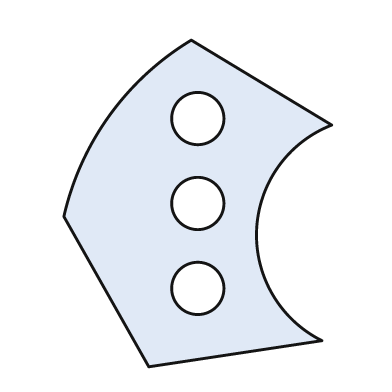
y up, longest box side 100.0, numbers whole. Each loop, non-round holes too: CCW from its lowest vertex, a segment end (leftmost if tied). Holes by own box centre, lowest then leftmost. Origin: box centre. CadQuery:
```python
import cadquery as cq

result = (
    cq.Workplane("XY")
    .moveTo(-15.0, -50.0)
    .lineTo(38.0, -42.0)
    .threePointArc((18.0, -8.0), (41.0, 24.0))
    .lineTo(-2.0, 50.0)
    .threePointArc((-27.0, 27.0), (-41.0, -4.0))
    .close()
    .moveTo(0.0, -26.0)
    .circle(8.0)
    .moveTo(0.0, 0.0)
    .circle(8.0)
    .moveTo(0.0, 26.0)
    .circle(8.0)
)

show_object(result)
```